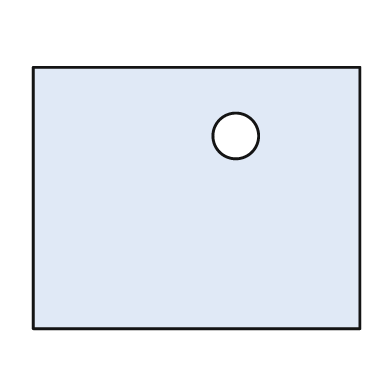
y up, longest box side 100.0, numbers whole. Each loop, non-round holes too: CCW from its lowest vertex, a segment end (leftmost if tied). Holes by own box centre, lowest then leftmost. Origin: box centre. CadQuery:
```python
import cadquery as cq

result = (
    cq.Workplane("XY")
    .moveTo(-50.0, -40.0)
    .lineTo(50.0, -40.0)
    .lineTo(50.0, 40.0)
    .lineTo(-50.0, 40.0)
    .close()
    .moveTo(12.0, 19.0)
    .circle(7.0)
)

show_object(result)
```